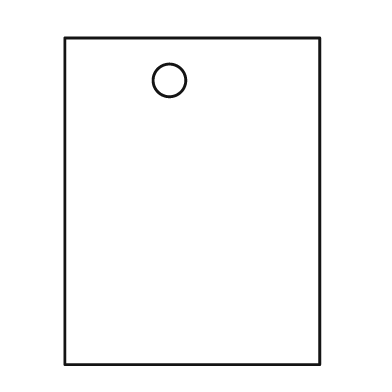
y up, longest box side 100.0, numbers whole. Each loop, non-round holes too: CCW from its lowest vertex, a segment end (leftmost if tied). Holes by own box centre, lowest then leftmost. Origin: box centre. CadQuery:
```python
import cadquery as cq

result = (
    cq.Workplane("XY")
    .moveTo(-39.0, -50.0)
    .lineTo(39.0, -50.0)
    .lineTo(39.0, 50.0)
    .lineTo(-39.0, 50.0)
    .close()
    .moveTo(-7.0, 37.0)
    .circle(5.0)
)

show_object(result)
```